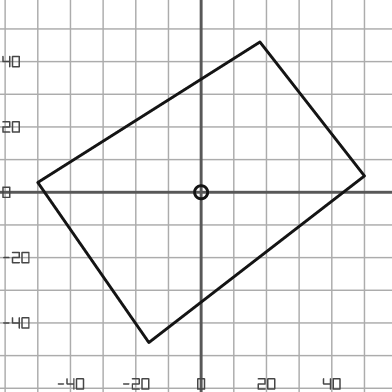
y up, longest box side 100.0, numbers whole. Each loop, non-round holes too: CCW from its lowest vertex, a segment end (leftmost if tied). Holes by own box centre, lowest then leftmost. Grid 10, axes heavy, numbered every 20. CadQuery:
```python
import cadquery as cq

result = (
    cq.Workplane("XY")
    .moveTo(-16.0, -46.0)
    .lineTo(50.0, 5.0)
    .lineTo(18.0, 46.0)
    .lineTo(-50.0, 3.0)
    .close()
    .moveTo(0.0, 0.0)
    .circle(2.0)
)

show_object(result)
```